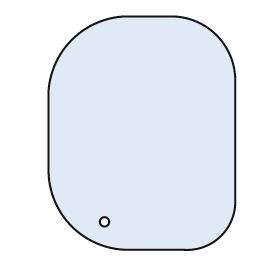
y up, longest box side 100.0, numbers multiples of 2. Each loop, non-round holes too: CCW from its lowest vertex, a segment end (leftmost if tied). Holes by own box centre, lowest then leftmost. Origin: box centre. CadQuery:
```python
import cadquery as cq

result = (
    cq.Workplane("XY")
    .moveTo(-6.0, -50.0)
    .lineTo(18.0, -50.0)
    .threePointArc((34.0, -44.0), (40.0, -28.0))
    .lineTo(40.0, 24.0)
    .threePointArc((32.0, 42.0), (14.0, 50.0))
    .lineTo(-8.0, 50.0)
    .threePointArc((-30.0, 40.0), (-40.0, 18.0))
    .lineTo(-40.0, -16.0)
    .threePointArc((-30.0, -40.0), (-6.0, -50.0))
    .close()
    .moveTo(-16.0, -38.0)
    .circle(2.0)
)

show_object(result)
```